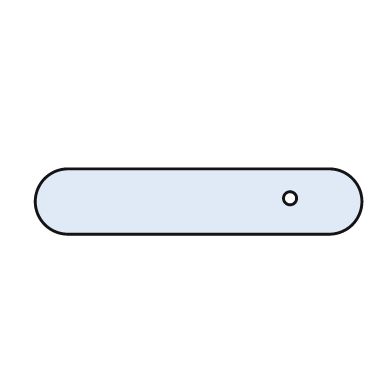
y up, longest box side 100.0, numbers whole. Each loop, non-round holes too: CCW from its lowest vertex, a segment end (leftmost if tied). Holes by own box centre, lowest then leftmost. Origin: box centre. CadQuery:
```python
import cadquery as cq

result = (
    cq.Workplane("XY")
    .moveTo(-40.0, -10.0)
    .lineTo(40.0, -10.0)
    .threePointArc((50.0, 0.0), (40.0, 10.0))
    .lineTo(-40.0, 10.0)
    .threePointArc((-50.0, 0.0), (-40.0, -10.0))
    .close()
    .moveTo(28.0, 1.0)
    .circle(2.0)
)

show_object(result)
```